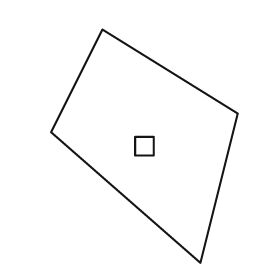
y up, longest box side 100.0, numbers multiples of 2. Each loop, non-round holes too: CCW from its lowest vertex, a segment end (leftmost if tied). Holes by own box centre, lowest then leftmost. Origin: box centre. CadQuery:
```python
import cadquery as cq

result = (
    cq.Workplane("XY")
    .moveTo(24.0, -50.0)
    .lineTo(40.0, 14.0)
    .lineTo(-18.0, 50.0)
    .lineTo(-40.0, 6.0)
    .close()
    .moveTo(-4.0, -4.0)
    .lineTo(4.0, -4.0)
    .lineTo(4.0, 4.0)
    .lineTo(-4.0, 4.0)
    .close()
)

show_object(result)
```